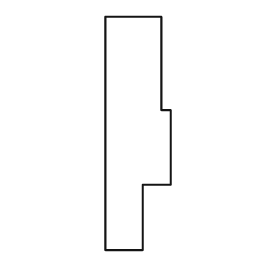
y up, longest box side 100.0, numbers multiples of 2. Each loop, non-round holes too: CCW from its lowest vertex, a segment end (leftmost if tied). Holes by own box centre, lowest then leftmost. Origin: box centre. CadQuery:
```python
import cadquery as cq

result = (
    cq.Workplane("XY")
    .moveTo(-14.0, -50.0)
    .lineTo(2.0, -50.0)
    .lineTo(2.0, -22.0)
    .lineTo(14.0, -22.0)
    .lineTo(14.0, 10.0)
    .lineTo(10.0, 10.0)
    .lineTo(10.0, 50.0)
    .lineTo(-14.0, 50.0)
    .close()
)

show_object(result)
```